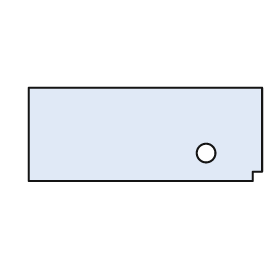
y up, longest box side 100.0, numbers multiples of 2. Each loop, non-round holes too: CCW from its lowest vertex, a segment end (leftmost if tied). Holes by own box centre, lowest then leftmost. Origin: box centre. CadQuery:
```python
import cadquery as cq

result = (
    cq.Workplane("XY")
    .moveTo(-50.0, -20.0)
    .lineTo(46.0, -20.0)
    .lineTo(46.0, -16.0)
    .lineTo(50.0, -16.0)
    .lineTo(50.0, 20.0)
    .lineTo(-50.0, 20.0)
    .close()
    .moveTo(26.0, -8.0)
    .circle(4.0)
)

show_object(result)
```